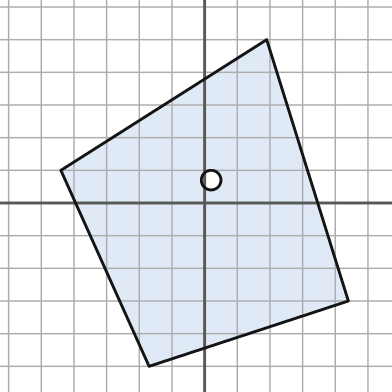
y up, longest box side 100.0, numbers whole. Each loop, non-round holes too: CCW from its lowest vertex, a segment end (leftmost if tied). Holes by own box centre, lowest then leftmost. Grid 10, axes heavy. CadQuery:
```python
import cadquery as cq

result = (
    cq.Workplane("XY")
    .moveTo(-17.0, -50.0)
    .lineTo(44.0, -30.0)
    .lineTo(19.0, 50.0)
    .lineTo(-44.0, 10.0)
    .close()
    .moveTo(2.0, 7.0)
    .circle(3.0)
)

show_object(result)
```